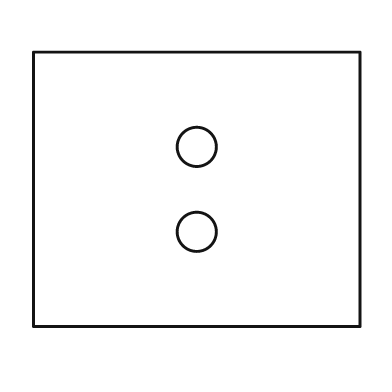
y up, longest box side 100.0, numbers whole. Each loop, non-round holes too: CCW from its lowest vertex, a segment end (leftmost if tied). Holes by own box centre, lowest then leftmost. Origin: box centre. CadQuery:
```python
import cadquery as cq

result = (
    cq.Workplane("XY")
    .moveTo(-50.0, -42.0)
    .lineTo(50.0, -42.0)
    .lineTo(50.0, 42.0)
    .lineTo(-50.0, 42.0)
    .close()
    .moveTo(0.0, -13.0)
    .circle(6.0)
    .moveTo(0.0, 13.0)
    .circle(6.0)
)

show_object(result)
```